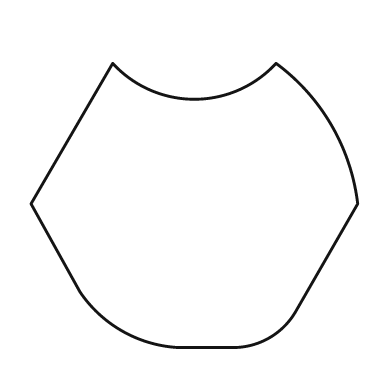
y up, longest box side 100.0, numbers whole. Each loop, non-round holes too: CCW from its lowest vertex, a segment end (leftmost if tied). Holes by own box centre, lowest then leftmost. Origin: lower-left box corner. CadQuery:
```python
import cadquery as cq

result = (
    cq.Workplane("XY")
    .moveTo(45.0, 0.0)
    .lineTo(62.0, 0.0)
    .threePointArc((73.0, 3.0), (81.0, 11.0))
    .lineTo(100.0, 44.0)
    .threePointArc((92.0, 68.0), (75.0, 87.0))
    .threePointArc((50.0, 76.0), (25.0, 87.0))
    .lineTo(0.0, 44.0)
    .lineTo(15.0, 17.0)
    .threePointArc((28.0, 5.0), (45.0, 0.0))
    .close()
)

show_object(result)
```